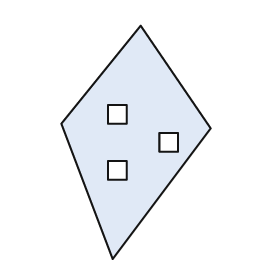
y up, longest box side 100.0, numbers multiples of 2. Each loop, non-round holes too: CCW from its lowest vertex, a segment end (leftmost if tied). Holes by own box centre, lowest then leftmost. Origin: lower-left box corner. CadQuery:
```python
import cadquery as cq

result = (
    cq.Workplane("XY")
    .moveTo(22.0, 0.0)
    .lineTo(64.0, 56.0)
    .lineTo(34.0, 100.0)
    .lineTo(0.0, 58.0)
    .close()
    .moveTo(20.0, 34.0)
    .lineTo(28.0, 34.0)
    .lineTo(28.0, 42.0)
    .lineTo(20.0, 42.0)
    .close()
    .moveTo(42.0, 46.0)
    .lineTo(50.0, 46.0)
    .lineTo(50.0, 54.0)
    .lineTo(42.0, 54.0)
    .close()
    .moveTo(20.0, 58.0)
    .lineTo(28.0, 58.0)
    .lineTo(28.0, 66.0)
    .lineTo(20.0, 66.0)
    .close()
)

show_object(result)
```